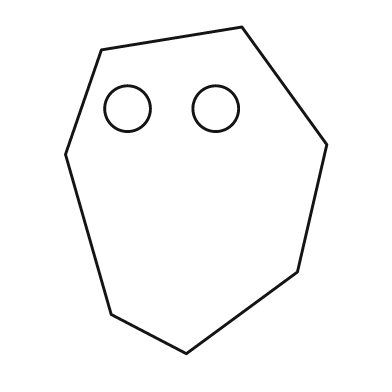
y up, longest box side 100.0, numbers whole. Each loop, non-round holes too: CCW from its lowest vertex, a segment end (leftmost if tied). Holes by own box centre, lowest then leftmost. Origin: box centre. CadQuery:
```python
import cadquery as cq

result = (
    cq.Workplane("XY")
    .moveTo(-3.0, -50.0)
    .lineTo(31.0, -25.0)
    .lineTo(40.0, 14.0)
    .lineTo(14.0, 50.0)
    .lineTo(-29.0, 43.0)
    .lineTo(-40.0, 11.0)
    .lineTo(-26.0, -38.0)
    .close()
    .moveTo(-21.0, 25.0)
    .circle(7.0)
    .moveTo(6.0, 25.0)
    .circle(7.0)
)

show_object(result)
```